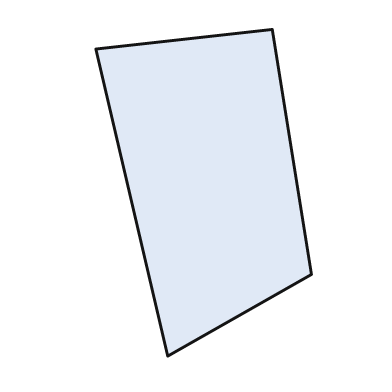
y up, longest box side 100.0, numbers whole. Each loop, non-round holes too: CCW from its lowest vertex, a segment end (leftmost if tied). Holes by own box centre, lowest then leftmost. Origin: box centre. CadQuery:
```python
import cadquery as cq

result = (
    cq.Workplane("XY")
    .moveTo(-11.0, -50.0)
    .lineTo(33.0, -25.0)
    .lineTo(21.0, 50.0)
    .lineTo(-33.0, 44.0)
    .close()
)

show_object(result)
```